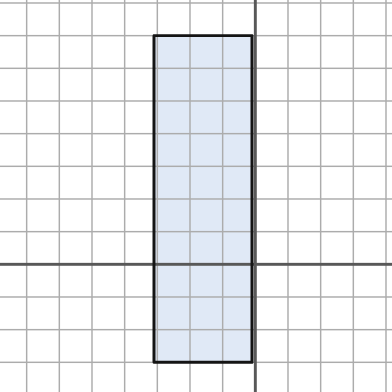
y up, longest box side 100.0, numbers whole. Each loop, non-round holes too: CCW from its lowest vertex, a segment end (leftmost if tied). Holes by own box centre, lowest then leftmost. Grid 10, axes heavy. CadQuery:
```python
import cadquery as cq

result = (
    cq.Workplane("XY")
    .moveTo(-31.0, -30.0)
    .lineTo(-1.0, -30.0)
    .lineTo(-1.0, 70.0)
    .lineTo(-31.0, 70.0)
    .close()
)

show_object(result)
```